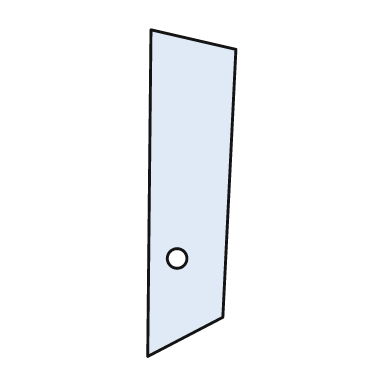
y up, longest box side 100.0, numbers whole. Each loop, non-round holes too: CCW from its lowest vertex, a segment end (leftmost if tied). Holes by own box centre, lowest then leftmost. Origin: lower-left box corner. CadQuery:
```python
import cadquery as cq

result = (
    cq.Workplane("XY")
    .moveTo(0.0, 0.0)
    .lineTo(23.0, 12.0)
    .lineTo(27.0, 94.0)
    .lineTo(1.0, 100.0)
    .close()
    .moveTo(9.0, 30.0)
    .circle(3.0)
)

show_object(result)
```